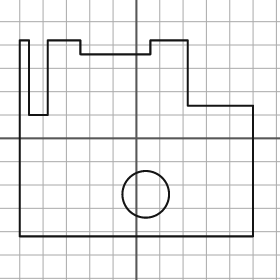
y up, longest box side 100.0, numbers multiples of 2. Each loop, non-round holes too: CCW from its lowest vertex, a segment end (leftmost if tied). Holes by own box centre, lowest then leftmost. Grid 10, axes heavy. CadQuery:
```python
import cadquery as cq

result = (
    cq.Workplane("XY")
    .moveTo(-50.0, -42.0)
    .lineTo(50.0, -42.0)
    .lineTo(50.0, 14.0)
    .lineTo(22.0, 14.0)
    .lineTo(22.0, 42.0)
    .lineTo(6.0, 42.0)
    .lineTo(6.0, 36.0)
    .lineTo(-24.0, 36.0)
    .lineTo(-24.0, 42.0)
    .lineTo(-38.0, 42.0)
    .lineTo(-38.0, 10.0)
    .lineTo(-46.0, 10.0)
    .lineTo(-46.0, 42.0)
    .lineTo(-50.0, 42.0)
    .close()
    .moveTo(4.0, -24.0)
    .circle(10.0)
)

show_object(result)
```